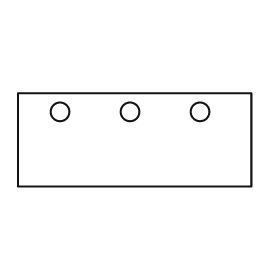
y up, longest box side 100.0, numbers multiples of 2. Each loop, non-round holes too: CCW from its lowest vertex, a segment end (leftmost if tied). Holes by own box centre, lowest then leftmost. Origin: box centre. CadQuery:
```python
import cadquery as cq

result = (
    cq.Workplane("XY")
    .moveTo(-50.0, -20.0)
    .lineTo(50.0, -20.0)
    .lineTo(50.0, 20.0)
    .lineTo(-50.0, 20.0)
    .close()
    .moveTo(-32.0, 12.0)
    .circle(4.0)
    .moveTo(-2.0, 12.0)
    .circle(4.0)
    .moveTo(28.0, 12.0)
    .circle(4.0)
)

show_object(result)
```